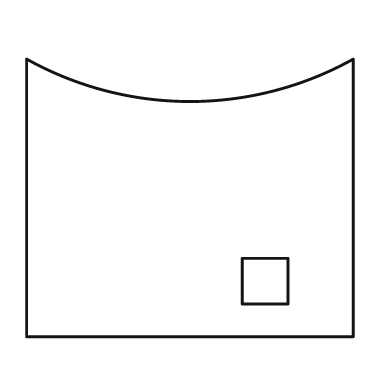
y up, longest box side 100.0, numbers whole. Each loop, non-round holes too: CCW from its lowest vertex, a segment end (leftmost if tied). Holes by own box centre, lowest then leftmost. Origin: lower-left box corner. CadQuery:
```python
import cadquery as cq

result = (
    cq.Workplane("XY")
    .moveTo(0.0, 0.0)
    .lineTo(100.0, 0.0)
    .lineTo(100.0, 85.0)
    .threePointArc((50.0, 72.0), (0.0, 85.0))
    .close()
    .moveTo(66.0, 10.0)
    .lineTo(80.0, 10.0)
    .lineTo(80.0, 24.0)
    .lineTo(66.0, 24.0)
    .close()
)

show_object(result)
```